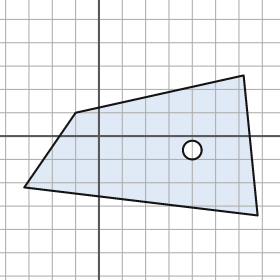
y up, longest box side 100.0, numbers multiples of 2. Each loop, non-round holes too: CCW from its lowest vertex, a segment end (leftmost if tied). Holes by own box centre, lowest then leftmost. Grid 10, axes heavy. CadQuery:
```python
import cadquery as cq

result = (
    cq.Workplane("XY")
    .moveTo(68.0, -34.0)
    .lineTo(62.0, 26.0)
    .lineTo(-10.0, 10.0)
    .lineTo(-32.0, -22.0)
    .close()
    .moveTo(40.0, -6.0)
    .circle(4.0)
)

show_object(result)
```